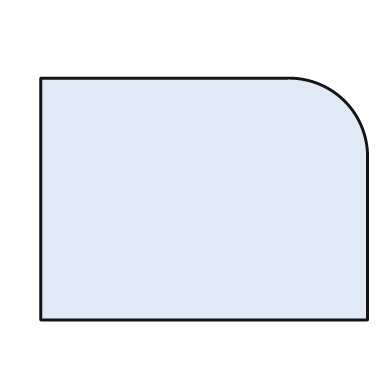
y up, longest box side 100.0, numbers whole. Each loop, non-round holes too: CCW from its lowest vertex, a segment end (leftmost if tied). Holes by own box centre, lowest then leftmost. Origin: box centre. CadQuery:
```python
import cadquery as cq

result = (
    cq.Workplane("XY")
    .moveTo(-50.0, -37.0)
    .lineTo(50.0, -37.0)
    .lineTo(50.0, 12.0)
    .threePointArc((43.0, 30.0), (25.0, 37.0))
    .lineTo(-50.0, 37.0)
    .close()
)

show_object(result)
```